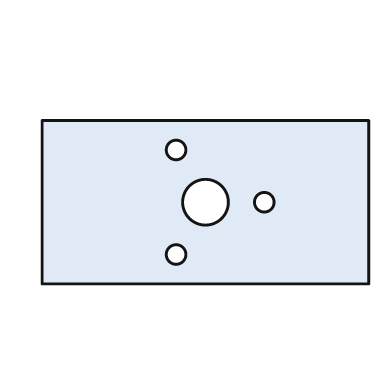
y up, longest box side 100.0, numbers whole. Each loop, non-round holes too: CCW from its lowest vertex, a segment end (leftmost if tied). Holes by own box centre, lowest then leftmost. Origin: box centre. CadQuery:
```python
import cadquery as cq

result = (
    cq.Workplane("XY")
    .moveTo(-50.0, -25.0)
    .lineTo(50.0, -25.0)
    .lineTo(50.0, 25.0)
    .lineTo(-50.0, 25.0)
    .close()
    .moveTo(-9.0, -16.0)
    .circle(3.0)
    .moveTo(0.0, 0.0)
    .circle(7.0)
    .moveTo(18.0, 0.0)
    .circle(3.0)
    .moveTo(-9.0, 16.0)
    .circle(3.0)
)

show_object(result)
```